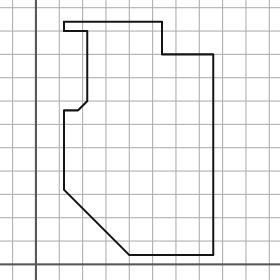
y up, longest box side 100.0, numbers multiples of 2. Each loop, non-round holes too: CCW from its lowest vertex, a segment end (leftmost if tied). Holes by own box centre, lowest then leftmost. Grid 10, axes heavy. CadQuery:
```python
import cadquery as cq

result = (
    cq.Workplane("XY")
    .moveTo(40.0, 4.0)
    .lineTo(76.0, 4.0)
    .lineTo(76.0, 90.0)
    .lineTo(54.0, 90.0)
    .lineTo(54.0, 104.0)
    .lineTo(12.0, 104.0)
    .lineTo(12.0, 100.0)
    .lineTo(22.0, 100.0)
    .lineTo(22.0, 70.0)
    .lineTo(18.0, 66.0)
    .lineTo(12.0, 66.0)
    .lineTo(12.0, 32.0)
    .close()
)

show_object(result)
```